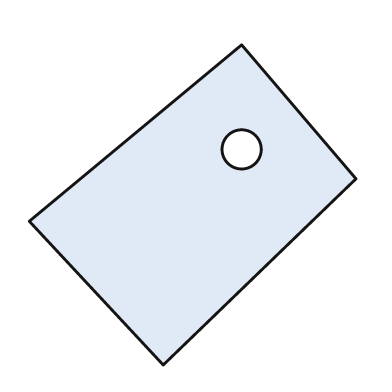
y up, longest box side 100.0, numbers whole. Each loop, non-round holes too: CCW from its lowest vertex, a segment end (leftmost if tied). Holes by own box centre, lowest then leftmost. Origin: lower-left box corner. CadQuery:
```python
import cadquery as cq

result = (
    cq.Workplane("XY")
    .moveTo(41.0, 0.0)
    .lineTo(100.0, 57.0)
    .lineTo(65.0, 98.0)
    .lineTo(0.0, 44.0)
    .close()
    .moveTo(65.0, 66.0)
    .circle(6.0)
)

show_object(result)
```